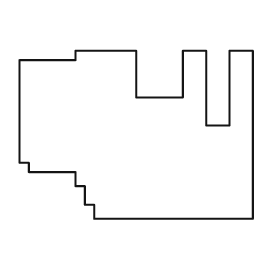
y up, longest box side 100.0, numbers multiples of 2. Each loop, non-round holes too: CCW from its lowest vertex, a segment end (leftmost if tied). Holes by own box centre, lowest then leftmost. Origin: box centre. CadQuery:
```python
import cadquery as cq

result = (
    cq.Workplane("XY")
    .moveTo(-18.0, -36.0)
    .lineTo(50.0, -36.0)
    .lineTo(50.0, 36.0)
    .lineTo(40.0, 36.0)
    .lineTo(40.0, 4.0)
    .lineTo(30.0, 4.0)
    .lineTo(30.0, 36.0)
    .lineTo(20.0, 36.0)
    .lineTo(20.0, 16.0)
    .lineTo(0.0, 16.0)
    .lineTo(0.0, 36.0)
    .lineTo(-26.0, 36.0)
    .lineTo(-26.0, 32.0)
    .lineTo(-50.0, 32.0)
    .lineTo(-50.0, -12.0)
    .lineTo(-46.0, -12.0)
    .lineTo(-46.0, -16.0)
    .lineTo(-26.0, -16.0)
    .lineTo(-26.0, -22.0)
    .lineTo(-22.0, -22.0)
    .lineTo(-22.0, -30.0)
    .lineTo(-18.0, -30.0)
    .close()
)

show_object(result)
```